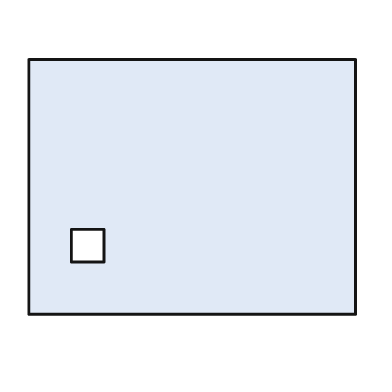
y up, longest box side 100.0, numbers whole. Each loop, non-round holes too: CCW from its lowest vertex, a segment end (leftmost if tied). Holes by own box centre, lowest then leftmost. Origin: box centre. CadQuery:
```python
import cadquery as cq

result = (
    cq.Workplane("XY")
    .moveTo(-50.0, -39.0)
    .lineTo(50.0, -39.0)
    .lineTo(50.0, 39.0)
    .lineTo(-50.0, 39.0)
    .close()
    .moveTo(-37.0, -23.0)
    .lineTo(-27.0, -23.0)
    .lineTo(-27.0, -13.0)
    .lineTo(-37.0, -13.0)
    .close()
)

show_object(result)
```